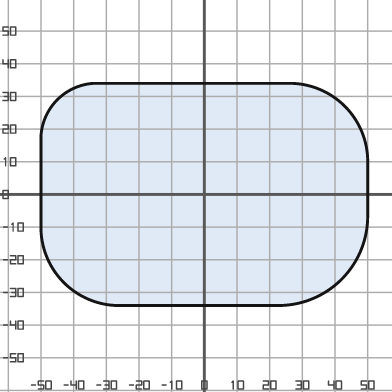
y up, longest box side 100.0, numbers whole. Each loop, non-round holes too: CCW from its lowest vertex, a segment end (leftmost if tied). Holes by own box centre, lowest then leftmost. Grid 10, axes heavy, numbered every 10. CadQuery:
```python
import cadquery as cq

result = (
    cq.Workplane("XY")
    .moveTo(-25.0, -34.0)
    .lineTo(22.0, -34.0)
    .threePointArc((42.0, -26.0), (50.0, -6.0))
    .lineTo(50.0, 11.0)
    .threePointArc((43.0, 27.0), (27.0, 34.0))
    .lineTo(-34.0, 34.0)
    .threePointArc((-45.0, 29.0), (-50.0, 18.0))
    .lineTo(-50.0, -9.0)
    .threePointArc((-43.0, -27.0), (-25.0, -34.0))
    .close()
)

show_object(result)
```